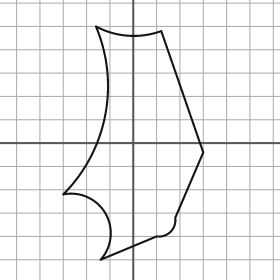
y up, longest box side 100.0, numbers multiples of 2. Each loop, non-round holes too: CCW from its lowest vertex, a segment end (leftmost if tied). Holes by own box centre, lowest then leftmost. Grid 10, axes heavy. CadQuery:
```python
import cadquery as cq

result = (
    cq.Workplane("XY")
    .moveTo(-14.0, -50.0)
    .lineTo(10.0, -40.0)
    .threePointArc((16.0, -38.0), (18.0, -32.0))
    .lineTo(30.0, -4.0)
    .lineTo(12.0, 48.0)
    .threePointArc((-2.0, 46.0), (-16.0, 50.0))
    .threePointArc((-12.0, 12.0), (-30.0, -22.0))
    .threePointArc((-12.0, -30.0), (-14.0, -50.0))
    .close()
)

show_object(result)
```